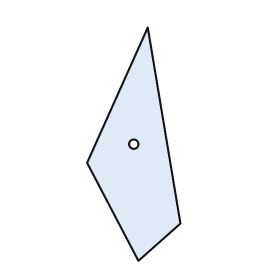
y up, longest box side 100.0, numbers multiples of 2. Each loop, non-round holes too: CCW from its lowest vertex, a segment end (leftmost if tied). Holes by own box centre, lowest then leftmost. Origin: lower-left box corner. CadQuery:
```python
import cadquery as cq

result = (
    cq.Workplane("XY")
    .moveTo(22.0, 0.0)
    .lineTo(40.0, 16.0)
    .lineTo(26.0, 100.0)
    .lineTo(0.0, 42.0)
    .close()
    .moveTo(20.0, 50.0)
    .circle(2.0)
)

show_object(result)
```